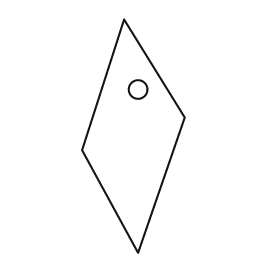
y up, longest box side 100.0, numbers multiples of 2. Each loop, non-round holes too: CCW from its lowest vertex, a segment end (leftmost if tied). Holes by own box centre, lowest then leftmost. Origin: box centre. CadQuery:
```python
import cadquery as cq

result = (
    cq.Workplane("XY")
    .moveTo(2.0, -50.0)
    .lineTo(22.0, 8.0)
    .lineTo(-4.0, 50.0)
    .lineTo(-22.0, -6.0)
    .close()
    .moveTo(2.0, 20.0)
    .circle(4.0)
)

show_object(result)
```